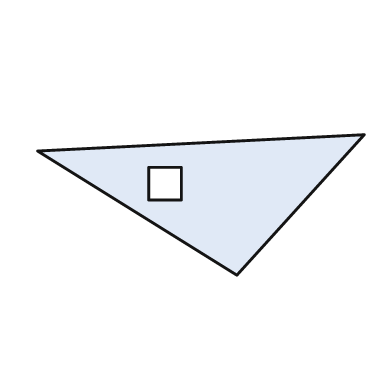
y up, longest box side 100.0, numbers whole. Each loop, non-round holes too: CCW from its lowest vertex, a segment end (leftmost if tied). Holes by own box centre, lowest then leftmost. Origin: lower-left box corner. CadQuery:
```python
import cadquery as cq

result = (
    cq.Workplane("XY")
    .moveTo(61.0, 0.0)
    .lineTo(100.0, 43.0)
    .lineTo(0.0, 38.0)
    .close()
    .moveTo(34.0, 23.0)
    .lineTo(44.0, 23.0)
    .lineTo(44.0, 33.0)
    .lineTo(34.0, 33.0)
    .close()
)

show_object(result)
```